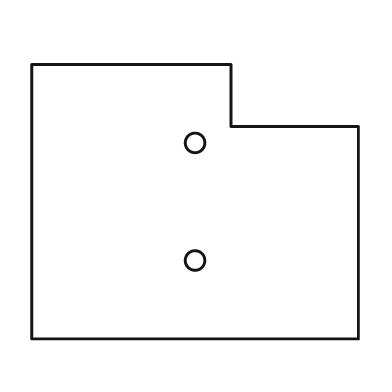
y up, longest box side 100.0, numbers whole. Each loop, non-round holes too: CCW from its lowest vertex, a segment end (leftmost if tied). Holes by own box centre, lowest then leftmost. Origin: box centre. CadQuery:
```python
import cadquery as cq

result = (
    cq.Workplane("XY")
    .moveTo(-50.0, -42.0)
    .lineTo(50.0, -42.0)
    .lineTo(50.0, 23.0)
    .lineTo(11.0, 23.0)
    .lineTo(11.0, 42.0)
    .lineTo(-50.0, 42.0)
    .close()
    .moveTo(0.0, -18.0)
    .circle(3.0)
    .moveTo(0.0, 18.0)
    .circle(3.0)
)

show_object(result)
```